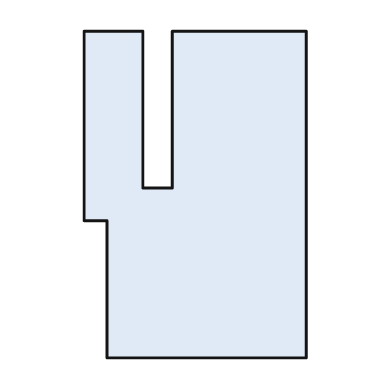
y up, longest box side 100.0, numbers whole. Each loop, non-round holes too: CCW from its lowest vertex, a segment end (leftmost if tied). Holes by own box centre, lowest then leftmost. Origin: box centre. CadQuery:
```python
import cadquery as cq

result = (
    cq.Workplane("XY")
    .moveTo(-27.0, -50.0)
    .lineTo(34.0, -50.0)
    .lineTo(34.0, 50.0)
    .lineTo(-7.0, 50.0)
    .lineTo(-7.0, 2.0)
    .lineTo(-16.0, 2.0)
    .lineTo(-16.0, 50.0)
    .lineTo(-34.0, 50.0)
    .lineTo(-34.0, -8.0)
    .lineTo(-27.0, -8.0)
    .close()
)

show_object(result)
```